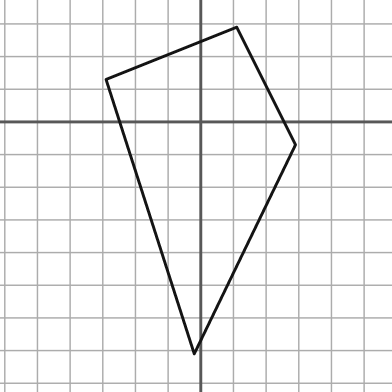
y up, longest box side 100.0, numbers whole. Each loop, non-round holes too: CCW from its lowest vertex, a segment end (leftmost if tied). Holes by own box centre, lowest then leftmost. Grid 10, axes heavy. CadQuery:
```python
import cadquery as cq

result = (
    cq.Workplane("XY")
    .moveTo(-2.0, -71.0)
    .lineTo(29.0, -7.0)
    .lineTo(11.0, 29.0)
    .lineTo(-29.0, 13.0)
    .close()
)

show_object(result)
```